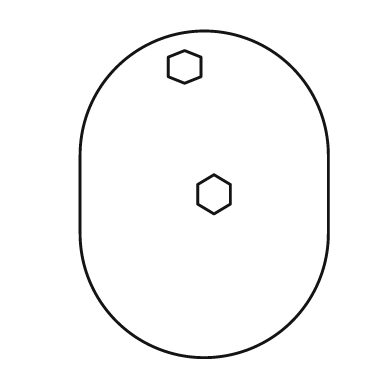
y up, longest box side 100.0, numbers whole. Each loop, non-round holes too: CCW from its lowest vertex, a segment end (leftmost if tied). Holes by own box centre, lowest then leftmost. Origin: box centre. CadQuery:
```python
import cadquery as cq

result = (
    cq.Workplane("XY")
    .moveTo(-38.0, -12.0)
    .threePointArc((0.0, -50.0), (38.0, -12.0))
    .lineTo(38.0, 12.0)
    .threePointArc((0.0, 50.0), (-38.0, 12.0))
    .close()
    .moveTo(3.0, -6.0)
    .lineTo(8.0, -3.0)
    .lineTo(8.0, 3.0)
    .lineTo(3.0, 6.0)
    .lineTo(-2.0, 3.0)
    .lineTo(-2.0, -3.0)
    .close()
    .moveTo(-6.0, 34.0)
    .lineTo(-1.0, 36.0)
    .lineTo(-1.0, 42.0)
    .lineTo(-6.0, 44.0)
    .lineTo(-11.0, 42.0)
    .lineTo(-11.0, 36.0)
    .close()
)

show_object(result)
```